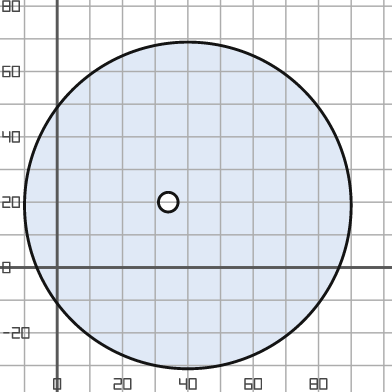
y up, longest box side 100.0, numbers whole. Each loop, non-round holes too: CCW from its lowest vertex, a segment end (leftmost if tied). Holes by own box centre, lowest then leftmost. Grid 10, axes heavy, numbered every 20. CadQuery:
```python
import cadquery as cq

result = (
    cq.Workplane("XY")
    .moveTo(40.0, 19.0)
    .circle(50.0)
    .moveTo(34.0, 20.0)
    .circle(3.0)
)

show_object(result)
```